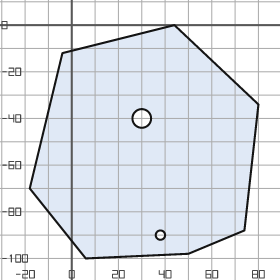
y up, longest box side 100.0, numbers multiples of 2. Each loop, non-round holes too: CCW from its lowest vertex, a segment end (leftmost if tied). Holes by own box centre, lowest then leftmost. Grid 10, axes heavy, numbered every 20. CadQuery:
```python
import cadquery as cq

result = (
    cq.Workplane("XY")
    .moveTo(6.0, -100.0)
    .lineTo(50.0, -98.0)
    .lineTo(74.0, -88.0)
    .lineTo(80.0, -34.0)
    .lineTo(44.0, 0.0)
    .lineTo(-4.0, -12.0)
    .lineTo(-18.0, -70.0)
    .close()
    .moveTo(38.0, -90.0)
    .circle(2.0)
    .moveTo(30.0, -40.0)
    .circle(4.0)
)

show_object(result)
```